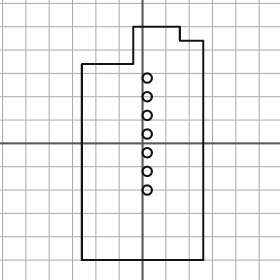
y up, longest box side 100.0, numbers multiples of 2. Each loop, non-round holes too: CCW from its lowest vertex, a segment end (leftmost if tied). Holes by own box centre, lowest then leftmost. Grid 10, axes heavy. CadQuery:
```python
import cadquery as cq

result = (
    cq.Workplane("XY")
    .moveTo(-26.0, -50.0)
    .lineTo(26.0, -50.0)
    .lineTo(26.0, 44.0)
    .lineTo(16.0, 44.0)
    .lineTo(16.0, 50.0)
    .lineTo(-4.0, 50.0)
    .lineTo(-4.0, 34.0)
    .lineTo(-26.0, 34.0)
    .close()
    .moveTo(2.0, -20.0)
    .circle(2.0)
    .moveTo(2.0, -12.0)
    .circle(2.0)
    .moveTo(2.0, -4.0)
    .circle(2.0)
    .moveTo(2.0, 4.0)
    .circle(2.0)
    .moveTo(2.0, 12.0)
    .circle(2.0)
    .moveTo(2.0, 20.0)
    .circle(2.0)
    .moveTo(2.0, 28.0)
    .circle(2.0)
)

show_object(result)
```